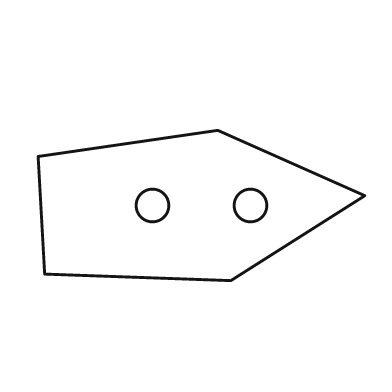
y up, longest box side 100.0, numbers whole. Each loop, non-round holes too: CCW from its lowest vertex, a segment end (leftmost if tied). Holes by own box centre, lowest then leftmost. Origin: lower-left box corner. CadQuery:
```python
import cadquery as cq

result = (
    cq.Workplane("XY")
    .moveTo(59.0, 0.0)
    .lineTo(100.0, 26.0)
    .lineTo(55.0, 46.0)
    .lineTo(0.0, 38.0)
    .lineTo(2.0, 2.0)
    .close()
    .moveTo(35.0, 23.0)
    .circle(5.0)
    .moveTo(65.0, 23.0)
    .circle(5.0)
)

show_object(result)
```